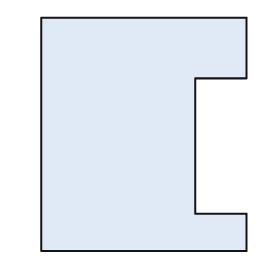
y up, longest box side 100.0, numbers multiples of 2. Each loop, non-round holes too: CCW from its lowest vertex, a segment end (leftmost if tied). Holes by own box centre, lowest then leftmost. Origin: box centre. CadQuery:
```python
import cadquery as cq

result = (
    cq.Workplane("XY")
    .moveTo(-44.0, -50.0)
    .lineTo(44.0, -50.0)
    .lineTo(44.0, -34.0)
    .lineTo(22.0, -34.0)
    .lineTo(22.0, 24.0)
    .lineTo(44.0, 24.0)
    .lineTo(44.0, 50.0)
    .lineTo(-44.0, 50.0)
    .close()
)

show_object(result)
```